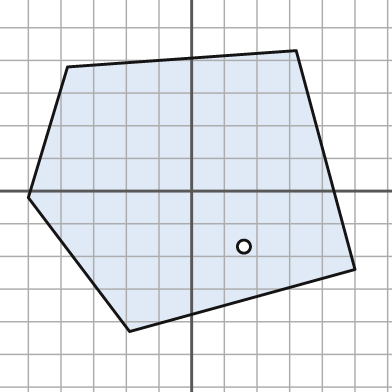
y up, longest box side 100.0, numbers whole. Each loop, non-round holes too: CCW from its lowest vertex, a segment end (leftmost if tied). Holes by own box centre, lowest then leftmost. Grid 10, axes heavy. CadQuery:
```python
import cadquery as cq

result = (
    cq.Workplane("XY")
    .moveTo(-19.0, -43.0)
    .lineTo(50.0, -24.0)
    .lineTo(32.0, 43.0)
    .lineTo(-38.0, 38.0)
    .lineTo(-50.0, -2.0)
    .close()
    .moveTo(16.0, -17.0)
    .circle(2.0)
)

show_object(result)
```